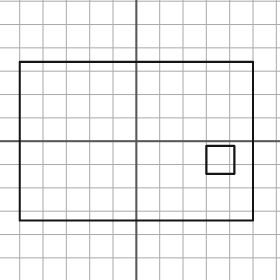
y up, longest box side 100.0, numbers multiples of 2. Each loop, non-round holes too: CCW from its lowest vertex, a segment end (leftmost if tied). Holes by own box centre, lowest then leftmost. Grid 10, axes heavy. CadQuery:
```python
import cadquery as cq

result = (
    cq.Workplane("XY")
    .moveTo(-50.0, -34.0)
    .lineTo(50.0, -34.0)
    .lineTo(50.0, 34.0)
    .lineTo(-50.0, 34.0)
    .close()
    .moveTo(30.0, -14.0)
    .lineTo(42.0, -14.0)
    .lineTo(42.0, -2.0)
    .lineTo(30.0, -2.0)
    .close()
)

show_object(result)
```